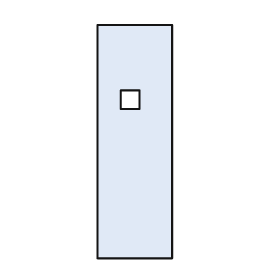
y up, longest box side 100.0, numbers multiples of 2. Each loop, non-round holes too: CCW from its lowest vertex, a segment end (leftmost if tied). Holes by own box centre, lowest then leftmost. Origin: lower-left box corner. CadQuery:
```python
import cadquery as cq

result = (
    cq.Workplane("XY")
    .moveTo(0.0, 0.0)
    .lineTo(32.0, 0.0)
    .lineTo(32.0, 100.0)
    .lineTo(0.0, 100.0)
    .close()
    .moveTo(10.0, 64.0)
    .lineTo(18.0, 64.0)
    .lineTo(18.0, 72.0)
    .lineTo(10.0, 72.0)
    .close()
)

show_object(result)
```